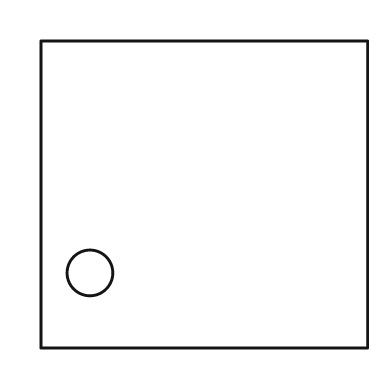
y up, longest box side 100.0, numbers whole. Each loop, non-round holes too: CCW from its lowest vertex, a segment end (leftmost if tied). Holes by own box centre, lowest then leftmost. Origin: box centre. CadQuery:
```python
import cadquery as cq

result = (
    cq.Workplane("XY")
    .moveTo(-50.0, -47.0)
    .lineTo(50.0, -47.0)
    .lineTo(50.0, 47.0)
    .lineTo(-50.0, 47.0)
    .close()
    .moveTo(-35.0, -24.0)
    .circle(7.0)
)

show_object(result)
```